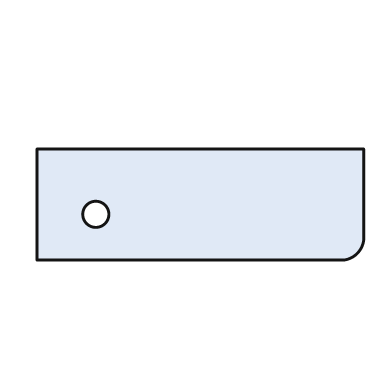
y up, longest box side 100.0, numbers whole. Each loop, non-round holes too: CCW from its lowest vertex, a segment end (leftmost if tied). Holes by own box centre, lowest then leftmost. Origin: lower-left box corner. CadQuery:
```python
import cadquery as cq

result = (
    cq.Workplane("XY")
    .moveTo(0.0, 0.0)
    .lineTo(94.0, 0.0)
    .threePointArc((98.0, 2.0), (100.0, 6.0))
    .lineTo(100.0, 34.0)
    .lineTo(0.0, 34.0)
    .close()
    .moveTo(18.0, 14.0)
    .circle(4.0)
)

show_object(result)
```